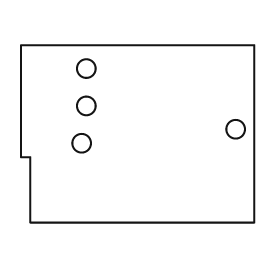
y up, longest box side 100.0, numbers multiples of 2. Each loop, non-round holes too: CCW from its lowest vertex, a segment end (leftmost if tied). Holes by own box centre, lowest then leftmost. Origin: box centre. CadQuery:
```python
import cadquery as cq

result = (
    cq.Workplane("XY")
    .moveTo(-46.0, -38.0)
    .lineTo(50.0, -38.0)
    .lineTo(50.0, 38.0)
    .lineTo(-50.0, 38.0)
    .lineTo(-50.0, -10.0)
    .lineTo(-46.0, -10.0)
    .close()
    .moveTo(-24.0, -4.0)
    .circle(4.0)
    .moveTo(42.0, 2.0)
    .circle(4.0)
    .moveTo(-22.0, 12.0)
    .circle(4.0)
    .moveTo(-22.0, 28.0)
    .circle(4.0)
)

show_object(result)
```